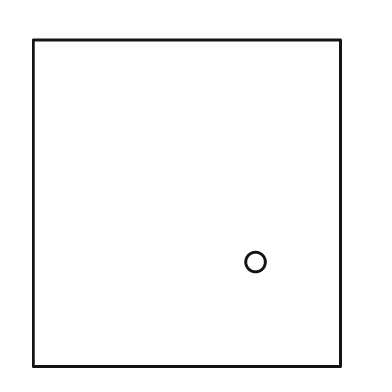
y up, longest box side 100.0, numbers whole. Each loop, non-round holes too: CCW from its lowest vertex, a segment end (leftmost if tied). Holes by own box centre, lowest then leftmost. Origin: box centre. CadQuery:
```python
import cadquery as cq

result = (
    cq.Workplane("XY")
    .moveTo(-47.0, -50.0)
    .lineTo(47.0, -50.0)
    .lineTo(47.0, 50.0)
    .lineTo(-47.0, 50.0)
    .close()
    .moveTo(21.0, -18.0)
    .circle(3.0)
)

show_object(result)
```